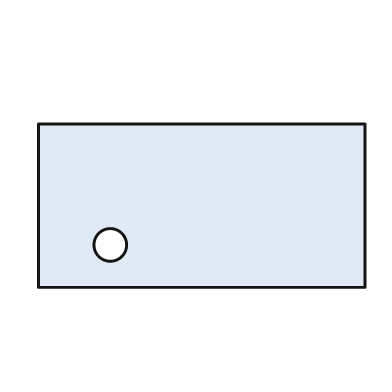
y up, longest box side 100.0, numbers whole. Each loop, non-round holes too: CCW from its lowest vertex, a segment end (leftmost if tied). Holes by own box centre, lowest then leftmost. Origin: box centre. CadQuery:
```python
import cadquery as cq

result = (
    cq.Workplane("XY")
    .moveTo(-50.0, -25.0)
    .lineTo(50.0, -25.0)
    .lineTo(50.0, 25.0)
    .lineTo(-50.0, 25.0)
    .close()
    .moveTo(-28.0, -12.0)
    .circle(5.0)
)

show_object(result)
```